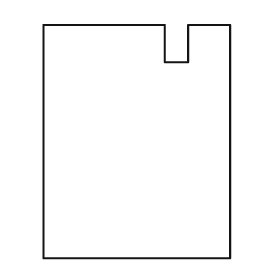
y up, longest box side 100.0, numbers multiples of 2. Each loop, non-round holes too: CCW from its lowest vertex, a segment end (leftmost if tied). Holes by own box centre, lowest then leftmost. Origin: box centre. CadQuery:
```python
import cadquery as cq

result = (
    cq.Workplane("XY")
    .moveTo(-40.0, -50.0)
    .lineTo(40.0, -50.0)
    .lineTo(40.0, 50.0)
    .lineTo(22.0, 50.0)
    .lineTo(22.0, 34.0)
    .lineTo(12.0, 34.0)
    .lineTo(12.0, 50.0)
    .lineTo(-40.0, 50.0)
    .close()
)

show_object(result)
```